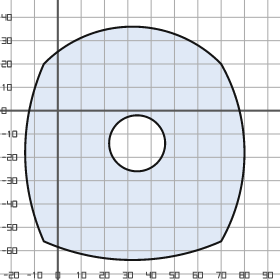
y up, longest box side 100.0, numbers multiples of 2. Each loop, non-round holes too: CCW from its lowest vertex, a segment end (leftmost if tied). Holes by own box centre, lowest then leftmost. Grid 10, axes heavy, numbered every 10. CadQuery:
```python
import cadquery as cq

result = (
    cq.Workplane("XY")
    .moveTo(-6.0, -56.0)
    .threePointArc((32.0, -64.0), (70.0, -56.0))
    .threePointArc((80.0, -18.0), (70.0, 20.0))
    .threePointArc((32.0, 36.0), (-6.0, 20.0))
    .threePointArc((-14.0, -18.0), (-6.0, -56.0))
    .close()
    .moveTo(34.0, -14.0)
    .circle(12.0)
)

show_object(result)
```